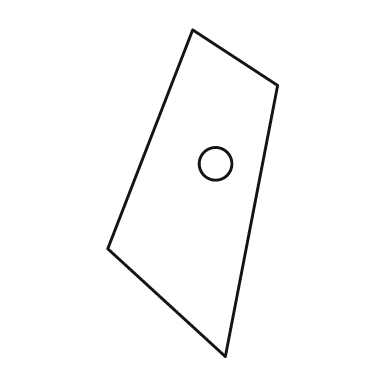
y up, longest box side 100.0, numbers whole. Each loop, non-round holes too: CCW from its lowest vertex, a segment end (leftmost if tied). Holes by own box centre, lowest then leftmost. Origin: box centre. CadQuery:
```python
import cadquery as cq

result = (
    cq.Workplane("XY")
    .moveTo(10.0, -50.0)
    .lineTo(26.0, 33.0)
    .lineTo(0.0, 50.0)
    .lineTo(-26.0, -17.0)
    .close()
    .moveTo(7.0, 9.0)
    .circle(5.0)
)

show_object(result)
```